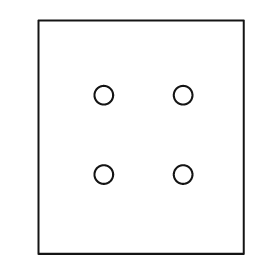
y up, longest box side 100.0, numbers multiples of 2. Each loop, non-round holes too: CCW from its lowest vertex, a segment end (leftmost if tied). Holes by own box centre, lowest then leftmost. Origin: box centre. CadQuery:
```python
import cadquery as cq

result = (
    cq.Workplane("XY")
    .moveTo(-44.0, -50.0)
    .lineTo(44.0, -50.0)
    .lineTo(44.0, 50.0)
    .lineTo(-44.0, 50.0)
    .close()
    .moveTo(-16.0, -16.0)
    .circle(4.0)
    .moveTo(18.0, -16.0)
    .circle(4.0)
    .moveTo(-16.0, 18.0)
    .circle(4.0)
    .moveTo(18.0, 18.0)
    .circle(4.0)
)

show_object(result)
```